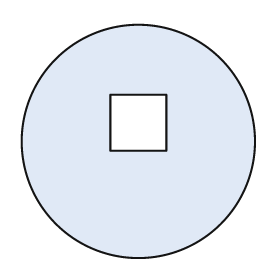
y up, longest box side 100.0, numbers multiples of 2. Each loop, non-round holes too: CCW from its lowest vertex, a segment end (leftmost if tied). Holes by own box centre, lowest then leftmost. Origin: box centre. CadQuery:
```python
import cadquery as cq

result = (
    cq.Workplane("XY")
    .moveTo(0.0, 0.0)
    .circle(50.0)
    .moveTo(-12.0, -4.0)
    .lineTo(12.0, -4.0)
    .lineTo(12.0, 20.0)
    .lineTo(-12.0, 20.0)
    .close()
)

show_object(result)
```